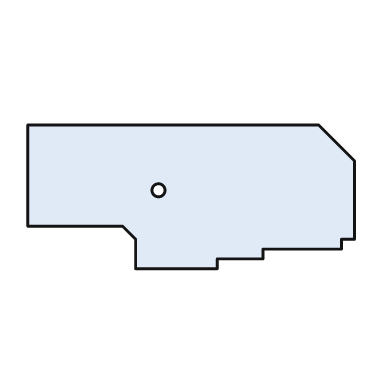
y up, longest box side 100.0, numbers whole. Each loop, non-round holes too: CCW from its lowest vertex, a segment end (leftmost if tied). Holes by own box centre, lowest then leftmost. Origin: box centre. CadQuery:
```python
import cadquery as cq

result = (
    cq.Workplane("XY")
    .moveTo(-17.0, -22.0)
    .lineTo(8.0, -22.0)
    .lineTo(8.0, -19.0)
    .lineTo(22.0, -19.0)
    .lineTo(22.0, -16.0)
    .lineTo(46.0, -16.0)
    .lineTo(46.0, -13.0)
    .lineTo(50.0, -13.0)
    .lineTo(50.0, 11.0)
    .lineTo(39.0, 22.0)
    .lineTo(-50.0, 22.0)
    .lineTo(-50.0, -9.0)
    .lineTo(-21.0, -9.0)
    .lineTo(-17.0, -13.0)
    .close()
    .moveTo(-10.0, 2.0)
    .circle(2.0)
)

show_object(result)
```